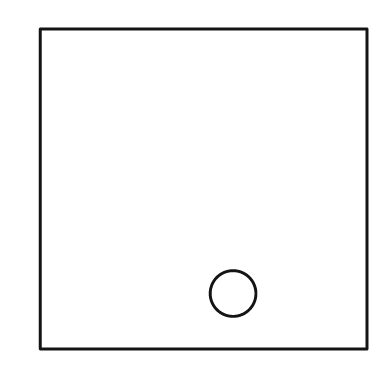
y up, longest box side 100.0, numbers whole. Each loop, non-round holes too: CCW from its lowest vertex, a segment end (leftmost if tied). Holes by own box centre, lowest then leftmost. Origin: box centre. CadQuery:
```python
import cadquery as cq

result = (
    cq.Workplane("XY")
    .moveTo(-50.0, -49.0)
    .lineTo(50.0, -49.0)
    .lineTo(50.0, 49.0)
    .lineTo(-50.0, 49.0)
    .close()
    .moveTo(9.0, -32.0)
    .circle(7.0)
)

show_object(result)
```